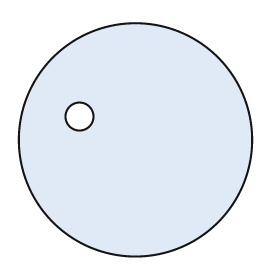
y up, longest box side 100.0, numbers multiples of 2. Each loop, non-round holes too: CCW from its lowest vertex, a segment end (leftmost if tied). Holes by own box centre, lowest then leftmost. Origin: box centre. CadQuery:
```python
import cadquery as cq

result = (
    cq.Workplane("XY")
    .moveTo(0.0, 0.0)
    .circle(50.0)
    .moveTo(-24.0, 10.0)
    .circle(6.0)
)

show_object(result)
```